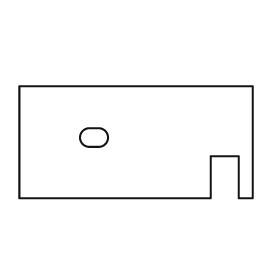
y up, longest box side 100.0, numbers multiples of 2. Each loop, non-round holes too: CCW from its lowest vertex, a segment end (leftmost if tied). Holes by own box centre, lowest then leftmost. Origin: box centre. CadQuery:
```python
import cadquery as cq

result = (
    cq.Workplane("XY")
    .moveTo(-50.0, -24.0)
    .lineTo(32.0, -24.0)
    .lineTo(32.0, -6.0)
    .lineTo(44.0, -6.0)
    .lineTo(44.0, -24.0)
    .lineTo(50.0, -24.0)
    .lineTo(50.0, 24.0)
    .lineTo(-50.0, 24.0)
    .close()
    .moveTo(-20.0, -2.0)
    .lineTo(-16.0, -2.0)
    .threePointArc((-12.0, 2.0), (-16.0, 6.0))
    .lineTo(-20.0, 6.0)
    .threePointArc((-24.0, 2.0), (-20.0, -2.0))
    .close()
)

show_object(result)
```